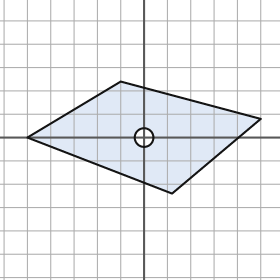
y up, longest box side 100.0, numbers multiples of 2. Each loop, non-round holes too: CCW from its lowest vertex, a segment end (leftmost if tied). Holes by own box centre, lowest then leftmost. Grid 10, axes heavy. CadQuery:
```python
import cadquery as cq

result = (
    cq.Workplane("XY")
    .moveTo(12.0, -24.0)
    .lineTo(50.0, 8.0)
    .lineTo(-10.0, 24.0)
    .lineTo(-50.0, 0.0)
    .close()
    .moveTo(0.0, 0.0)
    .circle(4.0)
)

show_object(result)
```